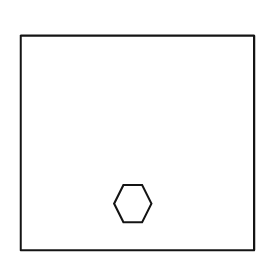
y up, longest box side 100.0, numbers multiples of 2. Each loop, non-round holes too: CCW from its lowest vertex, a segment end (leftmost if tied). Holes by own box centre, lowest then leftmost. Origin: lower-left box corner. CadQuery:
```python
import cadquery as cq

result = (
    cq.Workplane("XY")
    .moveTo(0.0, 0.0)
    .lineTo(100.0, 0.0)
    .lineTo(100.0, 92.0)
    .lineTo(0.0, 92.0)
    .close()
    .moveTo(44.0, 12.0)
    .lineTo(52.0, 12.0)
    .lineTo(56.0, 20.0)
    .lineTo(52.0, 28.0)
    .lineTo(44.0, 28.0)
    .lineTo(40.0, 20.0)
    .close()
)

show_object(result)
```